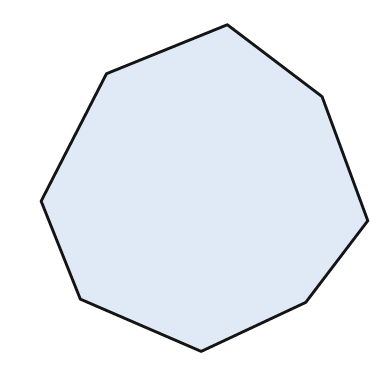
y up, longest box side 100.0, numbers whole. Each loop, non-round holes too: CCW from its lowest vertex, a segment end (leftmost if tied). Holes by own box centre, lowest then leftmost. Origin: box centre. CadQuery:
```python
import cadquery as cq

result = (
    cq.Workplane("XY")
    .moveTo(-1.0, -50.0)
    .lineTo(31.0, -35.0)
    .lineTo(50.0, -10.0)
    .lineTo(36.0, 28.0)
    .lineTo(7.0, 50.0)
    .lineTo(-30.0, 35.0)
    .lineTo(-50.0, -4.0)
    .lineTo(-38.0, -34.0)
    .close()
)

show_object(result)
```